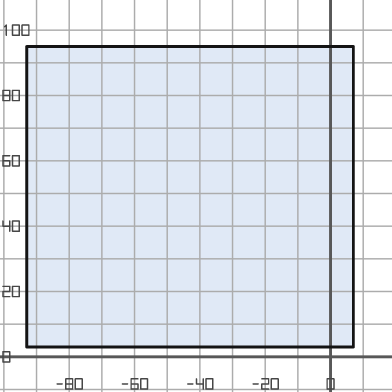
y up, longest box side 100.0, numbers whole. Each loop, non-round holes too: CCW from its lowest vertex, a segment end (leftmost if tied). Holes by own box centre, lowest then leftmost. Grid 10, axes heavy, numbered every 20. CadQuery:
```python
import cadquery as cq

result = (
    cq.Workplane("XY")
    .moveTo(-93.0, 3.0)
    .lineTo(7.0, 3.0)
    .lineTo(7.0, 95.0)
    .lineTo(-93.0, 95.0)
    .close()
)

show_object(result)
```